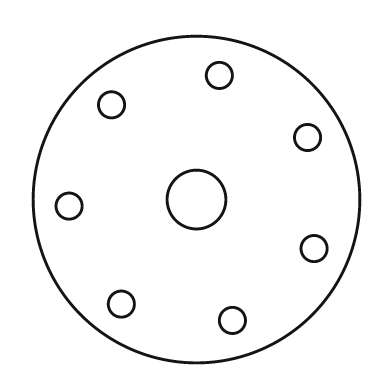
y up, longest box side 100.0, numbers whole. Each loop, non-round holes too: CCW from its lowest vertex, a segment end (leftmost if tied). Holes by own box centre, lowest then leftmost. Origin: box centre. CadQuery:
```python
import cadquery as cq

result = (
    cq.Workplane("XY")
    .moveTo(0.0, 0.0)
    .circle(50.0)
    .moveTo(11.0, -37.0)
    .circle(4.0)
    .moveTo(-23.0, -32.0)
    .circle(4.0)
    .moveTo(36.0, -15.0)
    .circle(4.0)
    .moveTo(-39.0, -2.0)
    .circle(4.0)
    .moveTo(0.0, 0.0)
    .circle(9.0)
    .moveTo(34.0, 19.0)
    .circle(4.0)
    .moveTo(-26.0, 29.0)
    .circle(4.0)
    .moveTo(7.0, 38.0)
    .circle(4.0)
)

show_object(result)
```